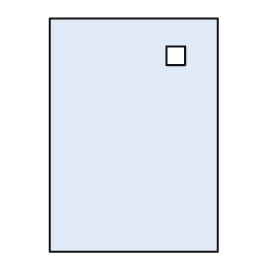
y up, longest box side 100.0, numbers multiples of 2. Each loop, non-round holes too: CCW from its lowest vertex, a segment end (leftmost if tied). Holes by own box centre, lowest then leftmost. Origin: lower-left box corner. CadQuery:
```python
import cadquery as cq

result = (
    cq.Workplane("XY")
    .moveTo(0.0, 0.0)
    .lineTo(72.0, 0.0)
    .lineTo(72.0, 100.0)
    .lineTo(0.0, 100.0)
    .close()
    .moveTo(50.0, 80.0)
    .lineTo(58.0, 80.0)
    .lineTo(58.0, 88.0)
    .lineTo(50.0, 88.0)
    .close()
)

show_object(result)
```